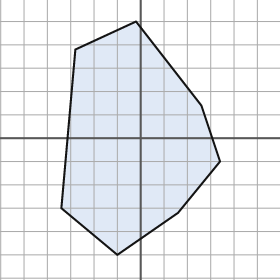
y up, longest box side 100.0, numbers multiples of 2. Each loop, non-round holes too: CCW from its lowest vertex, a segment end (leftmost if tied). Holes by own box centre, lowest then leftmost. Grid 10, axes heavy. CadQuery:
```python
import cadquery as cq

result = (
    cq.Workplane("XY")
    .moveTo(-10.0, -50.0)
    .lineTo(16.0, -32.0)
    .lineTo(34.0, -10.0)
    .lineTo(26.0, 14.0)
    .lineTo(-2.0, 50.0)
    .lineTo(-28.0, 38.0)
    .lineTo(-34.0, -30.0)
    .close()
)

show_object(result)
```